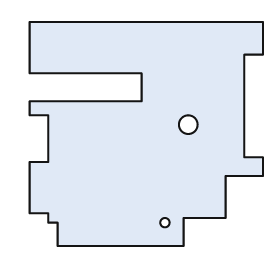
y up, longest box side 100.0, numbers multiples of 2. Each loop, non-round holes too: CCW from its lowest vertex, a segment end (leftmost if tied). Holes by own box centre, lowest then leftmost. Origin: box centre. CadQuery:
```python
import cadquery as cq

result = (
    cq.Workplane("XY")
    .moveTo(-38.0, -48.0)
    .lineTo(16.0, -48.0)
    .lineTo(16.0, -36.0)
    .lineTo(34.0, -36.0)
    .lineTo(34.0, -18.0)
    .lineTo(50.0, -18.0)
    .lineTo(50.0, -10.0)
    .lineTo(42.0, -10.0)
    .lineTo(42.0, 34.0)
    .lineTo(50.0, 34.0)
    .lineTo(50.0, 48.0)
    .lineTo(-50.0, 48.0)
    .lineTo(-50.0, 26.0)
    .lineTo(-2.0, 26.0)
    .lineTo(-2.0, 14.0)
    .lineTo(-50.0, 14.0)
    .lineTo(-50.0, 8.0)
    .lineTo(-42.0, 8.0)
    .lineTo(-42.0, -12.0)
    .lineTo(-50.0, -12.0)
    .lineTo(-50.0, -34.0)
    .lineTo(-42.0, -34.0)
    .lineTo(-42.0, -38.0)
    .lineTo(-38.0, -38.0)
    .close()
    .moveTo(8.0, -38.0)
    .circle(2.0)
    .moveTo(18.0, 4.0)
    .circle(4.0)
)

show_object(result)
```